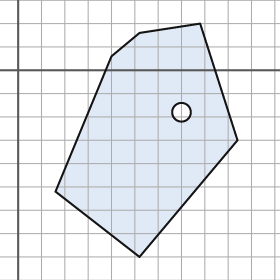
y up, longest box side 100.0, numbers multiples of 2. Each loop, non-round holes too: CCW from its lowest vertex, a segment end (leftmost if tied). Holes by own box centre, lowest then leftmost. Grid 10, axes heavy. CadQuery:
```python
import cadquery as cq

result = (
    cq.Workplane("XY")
    .moveTo(52.0, -80.0)
    .lineTo(94.0, -30.0)
    .lineTo(78.0, 20.0)
    .lineTo(52.0, 16.0)
    .lineTo(40.0, 6.0)
    .lineTo(16.0, -52.0)
    .close()
    .moveTo(70.0, -18.0)
    .circle(4.0)
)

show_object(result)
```